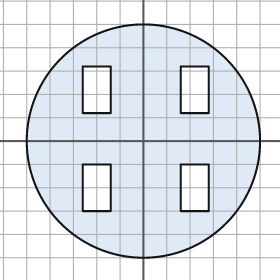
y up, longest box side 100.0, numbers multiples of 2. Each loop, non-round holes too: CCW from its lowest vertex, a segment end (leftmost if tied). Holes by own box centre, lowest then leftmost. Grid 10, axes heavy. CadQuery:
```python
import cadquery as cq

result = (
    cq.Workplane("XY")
    .moveTo(0.0, 0.0)
    .circle(50.0)
    .moveTo(-26.0, -30.0)
    .lineTo(-14.0, -30.0)
    .lineTo(-14.0, -10.0)
    .lineTo(-26.0, -10.0)
    .close()
    .moveTo(16.0, -30.0)
    .lineTo(28.0, -30.0)
    .lineTo(28.0, -10.0)
    .lineTo(16.0, -10.0)
    .close()
    .moveTo(-26.0, 12.0)
    .lineTo(-14.0, 12.0)
    .lineTo(-14.0, 32.0)
    .lineTo(-26.0, 32.0)
    .close()
    .moveTo(16.0, 12.0)
    .lineTo(28.0, 12.0)
    .lineTo(28.0, 32.0)
    .lineTo(16.0, 32.0)
    .close()
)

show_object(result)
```